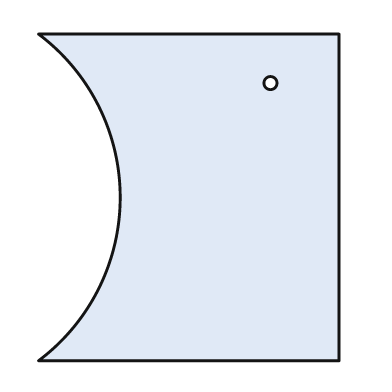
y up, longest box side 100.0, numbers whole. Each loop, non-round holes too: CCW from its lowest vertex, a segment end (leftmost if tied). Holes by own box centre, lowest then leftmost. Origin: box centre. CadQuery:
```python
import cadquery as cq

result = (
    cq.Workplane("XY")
    .moveTo(-46.0, -50.0)
    .lineTo(46.0, -50.0)
    .lineTo(46.0, 50.0)
    .lineTo(-46.0, 50.0)
    .threePointArc((-21.0, 0.0), (-46.0, -50.0))
    .close()
    .moveTo(25.0, 35.0)
    .circle(2.0)
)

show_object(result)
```